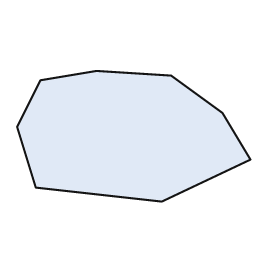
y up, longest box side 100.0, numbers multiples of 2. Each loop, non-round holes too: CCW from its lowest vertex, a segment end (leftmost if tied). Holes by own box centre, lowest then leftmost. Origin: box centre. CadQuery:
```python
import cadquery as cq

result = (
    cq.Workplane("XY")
    .moveTo(12.0, -28.0)
    .lineTo(50.0, -10.0)
    .lineTo(38.0, 10.0)
    .lineTo(16.0, 26.0)
    .lineTo(-16.0, 28.0)
    .lineTo(-40.0, 24.0)
    .lineTo(-50.0, 4.0)
    .lineTo(-42.0, -22.0)
    .close()
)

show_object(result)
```